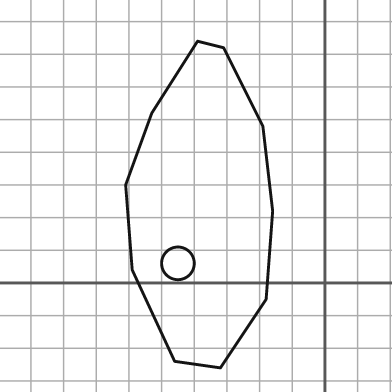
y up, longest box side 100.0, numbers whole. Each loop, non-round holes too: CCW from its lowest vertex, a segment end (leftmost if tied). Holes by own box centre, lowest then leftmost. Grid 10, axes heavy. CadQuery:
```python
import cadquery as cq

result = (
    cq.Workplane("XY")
    .moveTo(-32.0, -26.0)
    .lineTo(-18.0, -5.0)
    .lineTo(-16.0, 22.0)
    .lineTo(-19.0, 48.0)
    .lineTo(-31.0, 72.0)
    .lineTo(-39.0, 74.0)
    .lineTo(-53.0, 52.0)
    .lineTo(-61.0, 30.0)
    .lineTo(-59.0, 4.0)
    .lineTo(-46.0, -24.0)
    .close()
    .moveTo(-45.0, 6.0)
    .circle(5.0)
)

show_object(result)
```